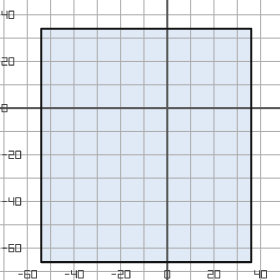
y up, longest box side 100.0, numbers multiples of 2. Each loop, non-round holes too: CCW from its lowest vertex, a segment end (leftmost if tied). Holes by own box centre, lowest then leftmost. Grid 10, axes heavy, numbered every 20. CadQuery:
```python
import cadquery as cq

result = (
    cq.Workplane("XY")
    .moveTo(-54.0, -66.0)
    .lineTo(36.0, -66.0)
    .lineTo(36.0, 34.0)
    .lineTo(-54.0, 34.0)
    .close()
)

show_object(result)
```